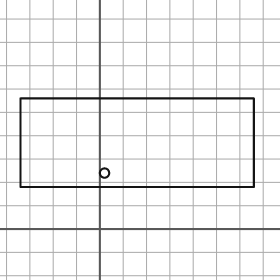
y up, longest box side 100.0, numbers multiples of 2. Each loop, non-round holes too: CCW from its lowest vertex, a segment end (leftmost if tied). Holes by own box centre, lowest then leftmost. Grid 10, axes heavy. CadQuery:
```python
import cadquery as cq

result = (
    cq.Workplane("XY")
    .moveTo(-34.0, 18.0)
    .lineTo(66.0, 18.0)
    .lineTo(66.0, 56.0)
    .lineTo(-34.0, 56.0)
    .close()
    .moveTo(2.0, 24.0)
    .circle(2.0)
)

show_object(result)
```